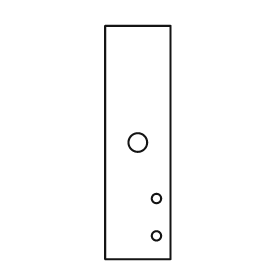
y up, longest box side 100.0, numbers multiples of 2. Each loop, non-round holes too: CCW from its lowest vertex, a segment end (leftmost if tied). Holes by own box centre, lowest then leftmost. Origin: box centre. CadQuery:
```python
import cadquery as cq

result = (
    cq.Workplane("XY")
    .moveTo(-14.0, -50.0)
    .lineTo(14.0, -50.0)
    .lineTo(14.0, 50.0)
    .lineTo(-14.0, 50.0)
    .close()
    .moveTo(8.0, -40.0)
    .circle(2.0)
    .moveTo(8.0, -24.0)
    .circle(2.0)
    .moveTo(0.0, 0.0)
    .circle(4.0)
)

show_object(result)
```